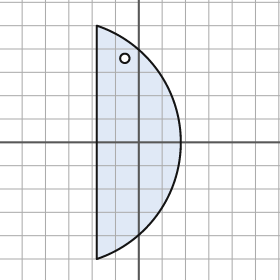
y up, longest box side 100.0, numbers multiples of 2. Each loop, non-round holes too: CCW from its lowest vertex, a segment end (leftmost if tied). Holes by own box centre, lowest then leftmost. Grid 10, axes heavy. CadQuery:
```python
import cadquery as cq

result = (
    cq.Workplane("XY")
    .moveTo(-18.0, -50.0)
    .threePointArc((18.0, 0.0), (-18.0, 50.0))
    .close()
    .moveTo(-6.0, 36.0)
    .circle(2.0)
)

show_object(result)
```